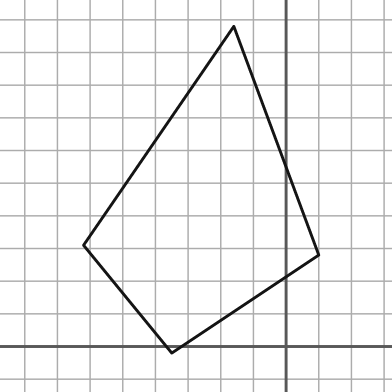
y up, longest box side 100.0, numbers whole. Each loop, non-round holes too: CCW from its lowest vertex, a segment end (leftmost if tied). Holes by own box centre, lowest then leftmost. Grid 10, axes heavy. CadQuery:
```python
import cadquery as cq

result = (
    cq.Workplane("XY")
    .moveTo(-35.0, -2.0)
    .lineTo(10.0, 28.0)
    .lineTo(-16.0, 98.0)
    .lineTo(-62.0, 31.0)
    .close()
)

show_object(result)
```